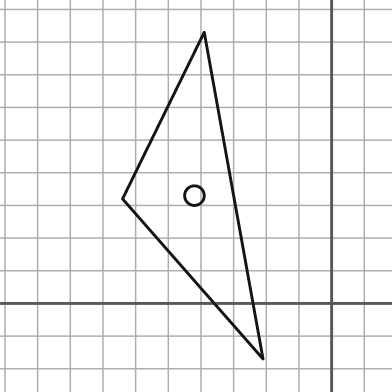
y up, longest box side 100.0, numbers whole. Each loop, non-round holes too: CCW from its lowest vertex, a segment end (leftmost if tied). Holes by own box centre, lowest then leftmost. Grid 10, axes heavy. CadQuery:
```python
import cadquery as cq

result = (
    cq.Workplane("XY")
    .moveTo(-21.0, -17.0)
    .lineTo(-39.0, 83.0)
    .lineTo(-64.0, 32.0)
    .close()
    .moveTo(-42.0, 33.0)
    .circle(3.0)
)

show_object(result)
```